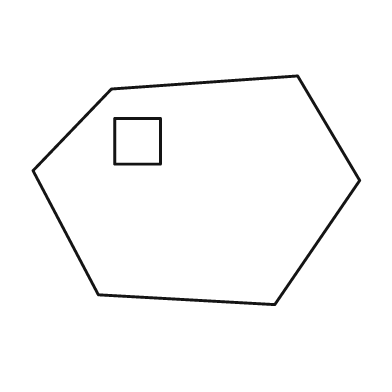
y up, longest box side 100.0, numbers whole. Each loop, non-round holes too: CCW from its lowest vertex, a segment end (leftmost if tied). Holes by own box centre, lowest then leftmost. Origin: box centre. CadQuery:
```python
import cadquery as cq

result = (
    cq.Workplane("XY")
    .moveTo(24.0, -35.0)
    .lineTo(50.0, 3.0)
    .lineTo(31.0, 35.0)
    .lineTo(-26.0, 31.0)
    .lineTo(-50.0, 6.0)
    .lineTo(-30.0, -32.0)
    .close()
    .moveTo(-25.0, 8.0)
    .lineTo(-11.0, 8.0)
    .lineTo(-11.0, 22.0)
    .lineTo(-25.0, 22.0)
    .close()
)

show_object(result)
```